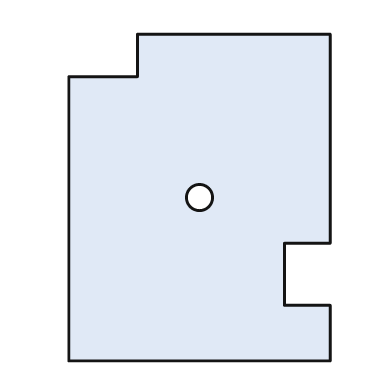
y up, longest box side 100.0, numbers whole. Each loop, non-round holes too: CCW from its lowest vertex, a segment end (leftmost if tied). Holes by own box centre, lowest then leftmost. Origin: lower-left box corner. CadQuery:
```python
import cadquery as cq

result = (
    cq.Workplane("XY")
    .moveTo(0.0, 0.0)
    .lineTo(80.0, 0.0)
    .lineTo(80.0, 17.0)
    .lineTo(66.0, 17.0)
    .lineTo(66.0, 36.0)
    .lineTo(80.0, 36.0)
    .lineTo(80.0, 100.0)
    .lineTo(21.0, 100.0)
    .lineTo(21.0, 87.0)
    .lineTo(0.0, 87.0)
    .close()
    .moveTo(40.0, 50.0)
    .circle(4.0)
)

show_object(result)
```